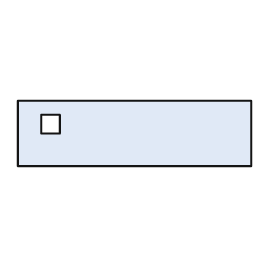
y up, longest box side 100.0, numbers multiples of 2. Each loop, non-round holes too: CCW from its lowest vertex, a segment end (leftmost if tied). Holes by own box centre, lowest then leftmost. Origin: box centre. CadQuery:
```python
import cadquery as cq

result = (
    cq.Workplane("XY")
    .moveTo(-50.0, -14.0)
    .lineTo(50.0, -14.0)
    .lineTo(50.0, 14.0)
    .lineTo(-50.0, 14.0)
    .close()
    .moveTo(-40.0, 0.0)
    .lineTo(-32.0, 0.0)
    .lineTo(-32.0, 8.0)
    .lineTo(-40.0, 8.0)
    .close()
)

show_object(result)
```